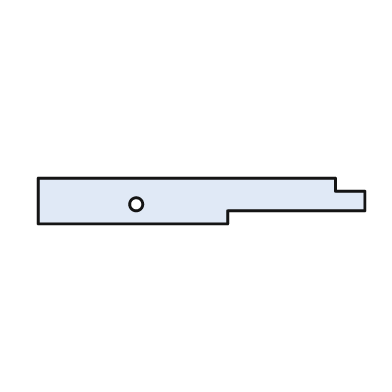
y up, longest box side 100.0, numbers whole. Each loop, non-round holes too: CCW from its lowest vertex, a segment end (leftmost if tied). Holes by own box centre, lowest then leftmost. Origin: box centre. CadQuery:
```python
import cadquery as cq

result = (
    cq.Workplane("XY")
    .moveTo(-50.0, -7.0)
    .lineTo(8.0, -7.0)
    .lineTo(8.0, -3.0)
    .lineTo(50.0, -3.0)
    .lineTo(50.0, 3.0)
    .lineTo(41.0, 3.0)
    .lineTo(41.0, 7.0)
    .lineTo(-50.0, 7.0)
    .close()
    .moveTo(-20.0, -1.0)
    .circle(2.0)
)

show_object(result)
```